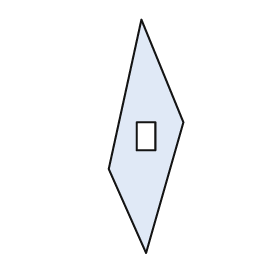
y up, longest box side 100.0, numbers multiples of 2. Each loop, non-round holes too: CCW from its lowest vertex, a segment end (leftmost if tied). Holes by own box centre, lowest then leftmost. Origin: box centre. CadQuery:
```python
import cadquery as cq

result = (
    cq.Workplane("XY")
    .moveTo(0.0, -50.0)
    .lineTo(16.0, 6.0)
    .lineTo(-2.0, 50.0)
    .lineTo(-16.0, -14.0)
    .close()
    .moveTo(-4.0, -6.0)
    .lineTo(4.0, -6.0)
    .lineTo(4.0, 6.0)
    .lineTo(-4.0, 6.0)
    .close()
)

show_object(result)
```